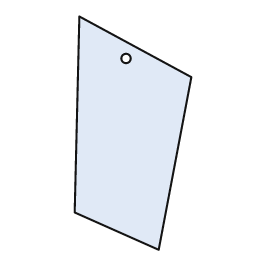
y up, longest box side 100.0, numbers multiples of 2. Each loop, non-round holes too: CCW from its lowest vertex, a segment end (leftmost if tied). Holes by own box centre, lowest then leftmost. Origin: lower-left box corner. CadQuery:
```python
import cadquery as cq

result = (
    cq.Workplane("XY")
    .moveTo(36.0, 0.0)
    .lineTo(50.0, 74.0)
    .lineTo(2.0, 100.0)
    .lineTo(0.0, 16.0)
    .close()
    .moveTo(22.0, 82.0)
    .circle(2.0)
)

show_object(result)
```